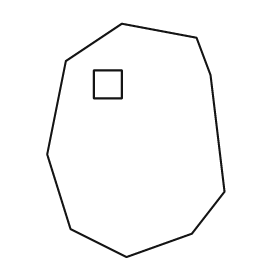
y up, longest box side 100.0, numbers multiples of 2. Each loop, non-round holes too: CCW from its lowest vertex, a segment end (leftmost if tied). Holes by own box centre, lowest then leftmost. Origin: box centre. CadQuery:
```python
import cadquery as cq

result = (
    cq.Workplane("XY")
    .moveTo(-4.0, -50.0)
    .lineTo(24.0, -40.0)
    .lineTo(38.0, -22.0)
    .lineTo(32.0, 28.0)
    .lineTo(26.0, 44.0)
    .lineTo(-6.0, 50.0)
    .lineTo(-30.0, 34.0)
    .lineTo(-38.0, -6.0)
    .lineTo(-28.0, -38.0)
    .close()
    .moveTo(-18.0, 18.0)
    .lineTo(-6.0, 18.0)
    .lineTo(-6.0, 30.0)
    .lineTo(-18.0, 30.0)
    .close()
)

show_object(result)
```